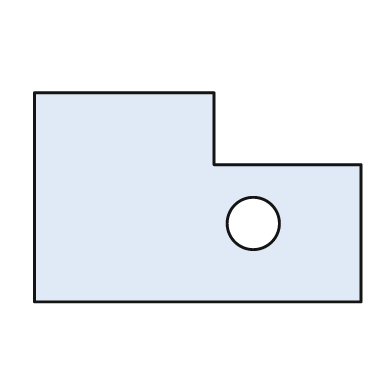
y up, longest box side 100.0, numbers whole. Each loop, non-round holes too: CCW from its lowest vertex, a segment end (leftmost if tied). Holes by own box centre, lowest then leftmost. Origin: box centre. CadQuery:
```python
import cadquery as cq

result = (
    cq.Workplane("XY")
    .moveTo(-50.0, -32.0)
    .lineTo(50.0, -32.0)
    .lineTo(50.0, 10.0)
    .lineTo(5.0, 10.0)
    .lineTo(5.0, 32.0)
    .lineTo(-50.0, 32.0)
    .close()
    .moveTo(17.0, -8.0)
    .circle(8.0)
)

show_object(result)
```